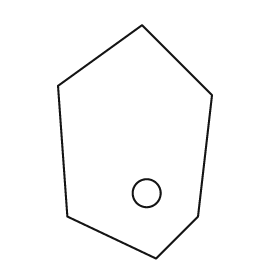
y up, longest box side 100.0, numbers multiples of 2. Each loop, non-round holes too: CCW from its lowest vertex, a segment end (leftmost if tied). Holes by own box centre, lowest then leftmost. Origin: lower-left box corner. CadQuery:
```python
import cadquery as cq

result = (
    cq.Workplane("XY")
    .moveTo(42.0, 0.0)
    .lineTo(60.0, 18.0)
    .lineTo(66.0, 70.0)
    .lineTo(36.0, 100.0)
    .lineTo(0.0, 74.0)
    .lineTo(4.0, 18.0)
    .close()
    .moveTo(38.0, 28.0)
    .circle(6.0)
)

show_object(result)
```